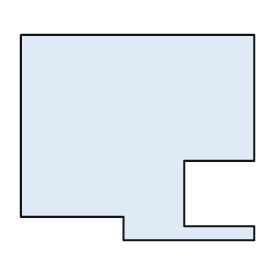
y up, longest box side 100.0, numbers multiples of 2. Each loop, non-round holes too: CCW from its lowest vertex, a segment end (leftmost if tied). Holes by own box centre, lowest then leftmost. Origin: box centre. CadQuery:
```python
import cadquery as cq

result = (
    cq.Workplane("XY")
    .moveTo(-6.0, -44.0)
    .lineTo(50.0, -44.0)
    .lineTo(50.0, -38.0)
    .lineTo(20.0, -38.0)
    .lineTo(20.0, -10.0)
    .lineTo(50.0, -10.0)
    .lineTo(50.0, 44.0)
    .lineTo(-50.0, 44.0)
    .lineTo(-50.0, -34.0)
    .lineTo(-6.0, -34.0)
    .close()
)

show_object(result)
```